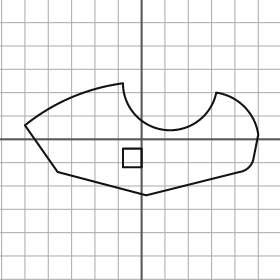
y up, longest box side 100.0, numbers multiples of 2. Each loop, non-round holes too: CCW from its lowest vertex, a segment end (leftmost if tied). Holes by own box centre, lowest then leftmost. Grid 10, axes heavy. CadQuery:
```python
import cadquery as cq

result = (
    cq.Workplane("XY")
    .moveTo(2.0, -24.0)
    .lineTo(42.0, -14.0)
    .threePointArc((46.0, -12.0), (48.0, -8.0))
    .lineTo(50.0, 2.0)
    .threePointArc((44.0, 14.0), (32.0, 20.0))
    .threePointArc((10.0, 4.0), (-8.0, 24.0))
    .threePointArc((-30.0, 18.0), (-50.0, 6.0))
    .lineTo(-36.0, -14.0)
    .close()
    .moveTo(-8.0, -12.0)
    .lineTo(0.0, -12.0)
    .lineTo(0.0, -4.0)
    .lineTo(-8.0, -4.0)
    .close()
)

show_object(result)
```